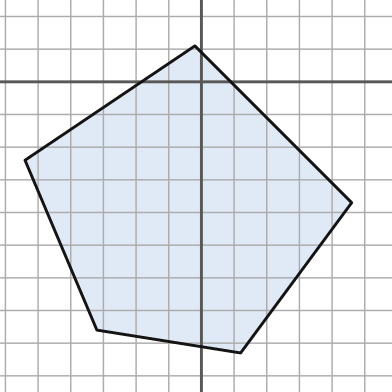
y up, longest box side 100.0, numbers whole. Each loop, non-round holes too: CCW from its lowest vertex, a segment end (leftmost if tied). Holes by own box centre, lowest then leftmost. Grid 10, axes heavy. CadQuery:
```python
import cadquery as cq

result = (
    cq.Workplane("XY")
    .moveTo(12.0, -83.0)
    .lineTo(46.0, -37.0)
    .lineTo(-2.0, 11.0)
    .lineTo(-54.0, -24.0)
    .lineTo(-32.0, -76.0)
    .close()
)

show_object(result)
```